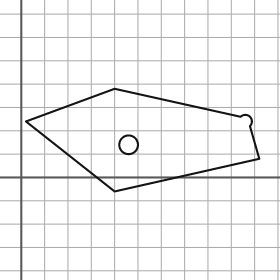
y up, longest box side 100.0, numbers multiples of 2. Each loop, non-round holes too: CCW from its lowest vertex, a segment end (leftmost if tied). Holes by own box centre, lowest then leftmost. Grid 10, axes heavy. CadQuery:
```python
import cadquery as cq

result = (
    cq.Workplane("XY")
    .moveTo(40.0, -6.0)
    .lineTo(102.0, 8.0)
    .lineTo(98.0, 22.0)
    .threePointArc((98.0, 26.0), (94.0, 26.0))
    .lineTo(40.0, 38.0)
    .lineTo(2.0, 24.0)
    .close()
    .moveTo(46.0, 14.0)
    .circle(4.0)
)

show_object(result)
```